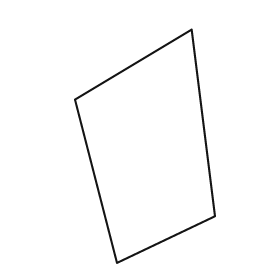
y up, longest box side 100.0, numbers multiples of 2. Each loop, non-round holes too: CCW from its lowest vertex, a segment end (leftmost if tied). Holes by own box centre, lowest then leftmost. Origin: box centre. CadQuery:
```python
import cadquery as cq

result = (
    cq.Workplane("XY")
    .moveTo(-12.0, -50.0)
    .lineTo(30.0, -30.0)
    .lineTo(20.0, 50.0)
    .lineTo(-30.0, 20.0)
    .close()
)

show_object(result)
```